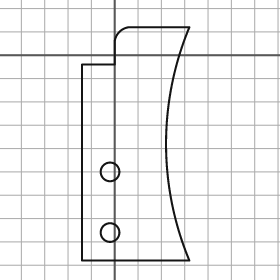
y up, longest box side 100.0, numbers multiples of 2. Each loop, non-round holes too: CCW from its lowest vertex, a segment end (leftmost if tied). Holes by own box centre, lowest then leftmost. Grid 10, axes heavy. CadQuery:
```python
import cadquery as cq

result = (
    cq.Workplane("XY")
    .moveTo(-14.0, -88.0)
    .lineTo(32.0, -88.0)
    .threePointArc((22.0, -38.0), (32.0, 12.0))
    .lineTo(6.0, 12.0)
    .threePointArc((2.0, 10.0), (0.0, 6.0))
    .lineTo(0.0, -4.0)
    .lineTo(-14.0, -4.0)
    .close()
    .moveTo(-2.0, -76.0)
    .circle(4.0)
    .moveTo(-2.0, -50.0)
    .circle(4.0)
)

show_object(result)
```